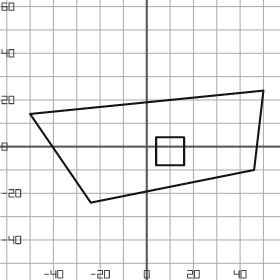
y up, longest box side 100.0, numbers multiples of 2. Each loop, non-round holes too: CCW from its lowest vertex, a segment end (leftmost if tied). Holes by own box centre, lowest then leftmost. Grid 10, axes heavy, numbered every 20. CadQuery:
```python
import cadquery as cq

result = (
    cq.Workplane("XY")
    .moveTo(-24.0, -24.0)
    .lineTo(46.0, -10.0)
    .lineTo(50.0, 24.0)
    .lineTo(-50.0, 14.0)
    .close()
    .moveTo(4.0, -8.0)
    .lineTo(16.0, -8.0)
    .lineTo(16.0, 4.0)
    .lineTo(4.0, 4.0)
    .close()
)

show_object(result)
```